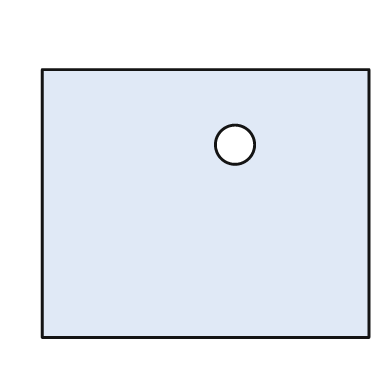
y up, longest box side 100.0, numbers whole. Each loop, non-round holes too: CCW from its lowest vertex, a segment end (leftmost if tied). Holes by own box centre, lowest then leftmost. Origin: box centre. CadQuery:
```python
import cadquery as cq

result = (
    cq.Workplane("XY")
    .moveTo(-50.0, -41.0)
    .lineTo(50.0, -41.0)
    .lineTo(50.0, 41.0)
    .lineTo(-50.0, 41.0)
    .close()
    .moveTo(9.0, 18.0)
    .circle(6.0)
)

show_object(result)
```